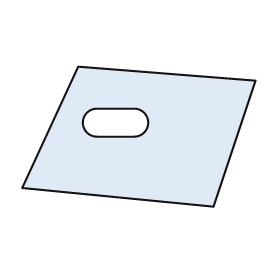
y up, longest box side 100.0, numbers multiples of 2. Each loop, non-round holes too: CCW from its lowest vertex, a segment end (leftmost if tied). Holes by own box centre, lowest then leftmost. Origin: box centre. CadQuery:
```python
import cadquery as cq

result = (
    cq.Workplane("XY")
    .moveTo(32.0, -30.0)
    .lineTo(50.0, 24.0)
    .lineTo(-26.0, 30.0)
    .lineTo(-50.0, -22.0)
    .close()
    .moveTo(-18.0, 0.0)
    .lineTo(-2.0, 0.0)
    .threePointArc((4.0, 6.0), (-2.0, 12.0))
    .lineTo(-18.0, 12.0)
    .threePointArc((-24.0, 6.0), (-18.0, 0.0))
    .close()
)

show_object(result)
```